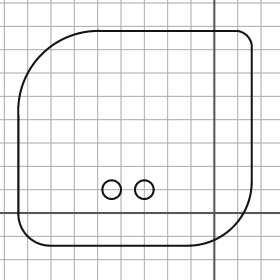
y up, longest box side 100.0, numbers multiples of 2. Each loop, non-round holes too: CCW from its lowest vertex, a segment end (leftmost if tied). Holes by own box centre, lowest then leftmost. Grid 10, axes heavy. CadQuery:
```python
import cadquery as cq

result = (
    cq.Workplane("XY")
    .moveTo(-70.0, -14.0)
    .lineTo(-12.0, -14.0)
    .threePointArc((8.0, -6.0), (16.0, 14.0))
    .lineTo(16.0, 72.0)
    .threePointArc((14.0, 76.0), (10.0, 78.0))
    .lineTo(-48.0, 78.0)
    .threePointArc((-74.0, 68.0), (-84.0, 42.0))
    .lineTo(-84.0, 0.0)
    .threePointArc((-80.0, -10.0), (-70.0, -14.0))
    .close()
    .moveTo(-44.0, 10.0)
    .circle(4.0)
    .moveTo(-30.0, 10.0)
    .circle(4.0)
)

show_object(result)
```